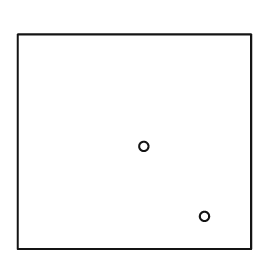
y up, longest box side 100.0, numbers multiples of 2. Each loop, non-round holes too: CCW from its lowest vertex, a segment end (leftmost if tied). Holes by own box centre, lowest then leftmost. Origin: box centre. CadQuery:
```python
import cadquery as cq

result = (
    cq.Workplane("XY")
    .moveTo(-50.0, -46.0)
    .lineTo(50.0, -46.0)
    .lineTo(50.0, 46.0)
    .lineTo(-50.0, 46.0)
    .close()
    .moveTo(30.0, -32.0)
    .circle(2.0)
    .moveTo(4.0, -2.0)
    .circle(2.0)
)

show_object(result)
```